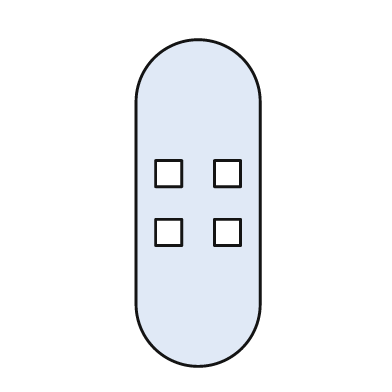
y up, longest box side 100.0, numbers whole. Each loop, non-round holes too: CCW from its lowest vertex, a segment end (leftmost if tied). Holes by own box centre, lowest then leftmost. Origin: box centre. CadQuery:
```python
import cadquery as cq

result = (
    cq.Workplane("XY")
    .moveTo(-19.0, -31.0)
    .threePointArc((0.0, -50.0), (19.0, -31.0))
    .lineTo(19.0, 31.0)
    .threePointArc((0.0, 50.0), (-19.0, 31.0))
    .close()
    .moveTo(-13.0, -13.0)
    .lineTo(-5.0, -13.0)
    .lineTo(-5.0, -5.0)
    .lineTo(-13.0, -5.0)
    .close()
    .moveTo(5.0, -13.0)
    .lineTo(13.0, -13.0)
    .lineTo(13.0, -5.0)
    .lineTo(5.0, -5.0)
    .close()
    .moveTo(-13.0, 5.0)
    .lineTo(-5.0, 5.0)
    .lineTo(-5.0, 13.0)
    .lineTo(-13.0, 13.0)
    .close()
    .moveTo(5.0, 5.0)
    .lineTo(13.0, 5.0)
    .lineTo(13.0, 13.0)
    .lineTo(5.0, 13.0)
    .close()
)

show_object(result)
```